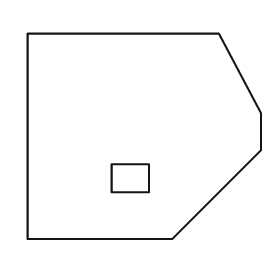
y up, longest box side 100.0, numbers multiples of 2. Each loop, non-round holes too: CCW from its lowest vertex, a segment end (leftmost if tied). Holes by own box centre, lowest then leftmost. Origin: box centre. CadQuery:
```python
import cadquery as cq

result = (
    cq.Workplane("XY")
    .moveTo(-50.0, -44.0)
    .lineTo(12.0, -44.0)
    .lineTo(50.0, -6.0)
    .lineTo(50.0, 10.0)
    .lineTo(32.0, 44.0)
    .lineTo(-50.0, 44.0)
    .close()
    .moveTo(-14.0, -24.0)
    .lineTo(2.0, -24.0)
    .lineTo(2.0, -12.0)
    .lineTo(-14.0, -12.0)
    .close()
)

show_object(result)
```